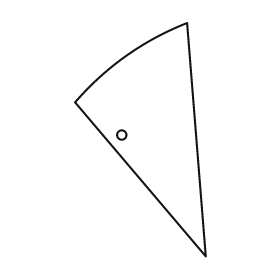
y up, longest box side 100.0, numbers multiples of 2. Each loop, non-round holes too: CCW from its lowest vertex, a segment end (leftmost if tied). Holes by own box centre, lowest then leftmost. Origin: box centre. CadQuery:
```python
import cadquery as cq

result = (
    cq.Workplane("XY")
    .moveTo(28.0, -50.0)
    .lineTo(20.0, 50.0)
    .threePointArc((-6.0, 36.0), (-28.0, 16.0))
    .close()
    .moveTo(-8.0, 2.0)
    .circle(2.0)
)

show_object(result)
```